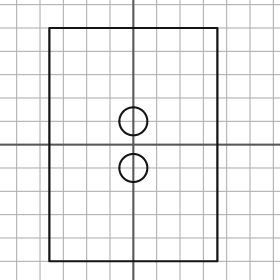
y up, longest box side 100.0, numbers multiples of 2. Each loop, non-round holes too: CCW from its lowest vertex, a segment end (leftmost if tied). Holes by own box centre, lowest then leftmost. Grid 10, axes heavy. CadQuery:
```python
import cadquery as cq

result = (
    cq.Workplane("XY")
    .moveTo(-36.0, -50.0)
    .lineTo(36.0, -50.0)
    .lineTo(36.0, 50.0)
    .lineTo(-36.0, 50.0)
    .close()
    .moveTo(0.0, -10.0)
    .circle(6.0)
    .moveTo(0.0, 10.0)
    .circle(6.0)
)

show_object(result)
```